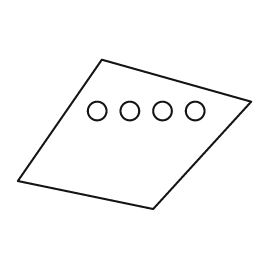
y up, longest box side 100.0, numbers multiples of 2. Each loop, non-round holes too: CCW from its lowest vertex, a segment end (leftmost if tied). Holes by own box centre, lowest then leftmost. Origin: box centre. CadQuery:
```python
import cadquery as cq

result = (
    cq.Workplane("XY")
    .moveTo(8.0, -32.0)
    .lineTo(50.0, 14.0)
    .lineTo(-14.0, 32.0)
    .lineTo(-50.0, -20.0)
    .close()
    .moveTo(-16.0, 10.0)
    .circle(4.0)
    .moveTo(-2.0, 10.0)
    .circle(4.0)
    .moveTo(12.0, 10.0)
    .circle(4.0)
    .moveTo(26.0, 10.0)
    .circle(4.0)
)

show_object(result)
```